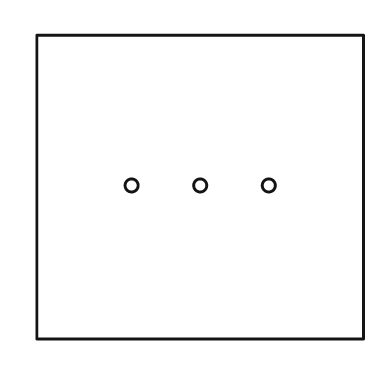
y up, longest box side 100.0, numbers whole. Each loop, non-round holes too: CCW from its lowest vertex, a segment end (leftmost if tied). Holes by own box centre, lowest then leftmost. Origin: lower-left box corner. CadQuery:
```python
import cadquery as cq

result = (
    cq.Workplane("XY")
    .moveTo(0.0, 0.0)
    .lineTo(100.0, 0.0)
    .lineTo(100.0, 93.0)
    .lineTo(0.0, 93.0)
    .close()
    .moveTo(29.0, 47.0)
    .circle(2.0)
    .moveTo(50.0, 47.0)
    .circle(2.0)
    .moveTo(71.0, 47.0)
    .circle(2.0)
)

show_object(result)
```